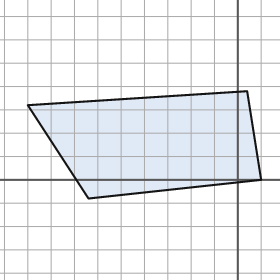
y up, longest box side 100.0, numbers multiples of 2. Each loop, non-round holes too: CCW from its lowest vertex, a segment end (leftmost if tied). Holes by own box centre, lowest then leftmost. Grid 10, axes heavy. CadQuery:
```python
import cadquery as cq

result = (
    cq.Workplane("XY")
    .moveTo(-64.0, -8.0)
    .lineTo(10.0, 0.0)
    .lineTo(4.0, 38.0)
    .lineTo(-90.0, 32.0)
    .close()
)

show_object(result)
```